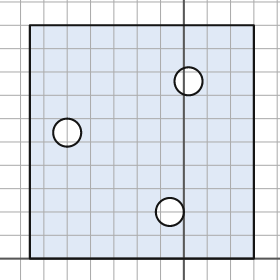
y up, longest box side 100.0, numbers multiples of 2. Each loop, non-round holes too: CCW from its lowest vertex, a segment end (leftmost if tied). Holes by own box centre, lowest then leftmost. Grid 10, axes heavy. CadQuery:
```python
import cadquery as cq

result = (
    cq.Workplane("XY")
    .moveTo(-66.0, 0.0)
    .lineTo(30.0, 0.0)
    .lineTo(30.0, 100.0)
    .lineTo(-66.0, 100.0)
    .close()
    .moveTo(-6.0, 20.0)
    .circle(6.0)
    .moveTo(-50.0, 54.0)
    .circle(6.0)
    .moveTo(2.0, 76.0)
    .circle(6.0)
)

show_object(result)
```